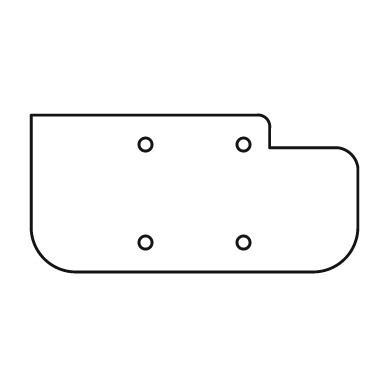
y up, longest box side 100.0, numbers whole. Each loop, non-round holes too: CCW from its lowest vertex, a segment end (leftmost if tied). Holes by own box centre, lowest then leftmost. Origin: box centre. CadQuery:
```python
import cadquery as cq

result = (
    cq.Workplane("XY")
    .moveTo(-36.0, -24.0)
    .lineTo(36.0, -24.0)
    .threePointArc((46.0, -20.0), (50.0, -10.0))
    .lineTo(50.0, 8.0)
    .threePointArc((48.0, 12.0), (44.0, 14.0))
    .lineTo(23.0, 14.0)
    .lineTo(23.0, 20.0)
    .threePointArc((22.0, 23.0), (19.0, 24.0))
    .lineTo(-50.0, 24.0)
    .lineTo(-50.0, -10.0)
    .threePointArc((-46.0, -20.0), (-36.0, -24.0))
    .close()
    .moveTo(-15.0, -15.0)
    .circle(2.0)
    .moveTo(15.0, -15.0)
    .circle(2.0)
    .moveTo(-15.0, 15.0)
    .circle(2.0)
    .moveTo(15.0, 15.0)
    .circle(2.0)
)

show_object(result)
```